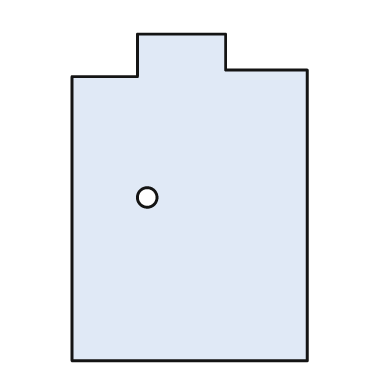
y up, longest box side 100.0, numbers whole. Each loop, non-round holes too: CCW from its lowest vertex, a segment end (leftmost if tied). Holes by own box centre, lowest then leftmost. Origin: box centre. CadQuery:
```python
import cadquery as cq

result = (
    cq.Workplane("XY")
    .moveTo(-36.0, -50.0)
    .lineTo(36.0, -50.0)
    .lineTo(36.0, 39.0)
    .lineTo(11.0, 39.0)
    .lineTo(11.0, 50.0)
    .lineTo(-16.0, 50.0)
    .lineTo(-16.0, 37.0)
    .lineTo(-36.0, 37.0)
    .close()
    .moveTo(-13.0, 0.0)
    .circle(3.0)
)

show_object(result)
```